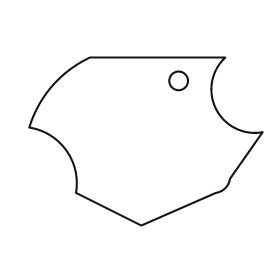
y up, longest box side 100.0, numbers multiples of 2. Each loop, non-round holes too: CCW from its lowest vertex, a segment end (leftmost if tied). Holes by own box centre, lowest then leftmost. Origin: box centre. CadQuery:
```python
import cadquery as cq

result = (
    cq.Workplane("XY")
    .moveTo(-2.0, -36.0)
    .lineTo(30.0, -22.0)
    .threePointArc((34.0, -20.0), (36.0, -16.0))
    .lineTo(50.0, 4.0)
    .threePointArc((30.0, 14.0), (34.0, 36.0))
    .lineTo(-24.0, 36.0)
    .threePointArc((-40.0, 24.0), (-50.0, 6.0))
    .threePointArc((-34.0, -4.0), (-30.0, -22.0))
    .close()
    .moveTo(14.0, 26.0)
    .circle(4.0)
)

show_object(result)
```